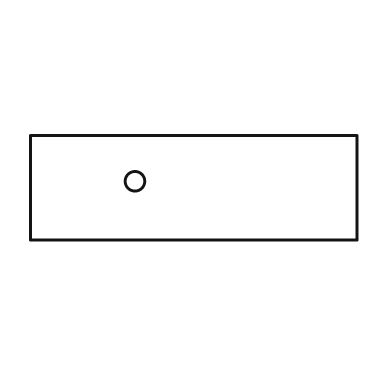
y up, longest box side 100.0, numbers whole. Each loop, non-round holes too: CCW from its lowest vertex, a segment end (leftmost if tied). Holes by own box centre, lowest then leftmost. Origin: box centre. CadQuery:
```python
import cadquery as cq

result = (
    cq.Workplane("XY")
    .moveTo(-50.0, -16.0)
    .lineTo(50.0, -16.0)
    .lineTo(50.0, 16.0)
    .lineTo(-50.0, 16.0)
    .close()
    .moveTo(-18.0, 2.0)
    .circle(3.0)
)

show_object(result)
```